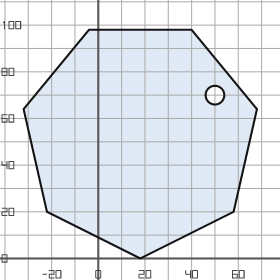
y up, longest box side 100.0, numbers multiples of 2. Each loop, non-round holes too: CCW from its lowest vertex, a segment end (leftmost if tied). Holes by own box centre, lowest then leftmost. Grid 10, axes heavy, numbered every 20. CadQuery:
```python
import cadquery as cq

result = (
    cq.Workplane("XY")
    .moveTo(18.0, 0.0)
    .lineTo(58.0, 20.0)
    .lineTo(68.0, 64.0)
    .lineTo(40.0, 98.0)
    .lineTo(-4.0, 98.0)
    .lineTo(-32.0, 64.0)
    .lineTo(-22.0, 20.0)
    .close()
    .moveTo(50.0, 70.0)
    .circle(4.0)
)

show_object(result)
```